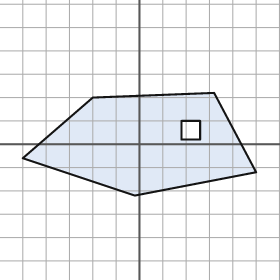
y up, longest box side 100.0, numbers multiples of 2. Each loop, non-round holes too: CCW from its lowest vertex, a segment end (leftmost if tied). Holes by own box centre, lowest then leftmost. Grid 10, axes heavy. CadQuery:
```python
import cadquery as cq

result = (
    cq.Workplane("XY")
    .moveTo(-2.0, -22.0)
    .lineTo(50.0, -12.0)
    .lineTo(32.0, 22.0)
    .lineTo(-20.0, 20.0)
    .lineTo(-50.0, -6.0)
    .close()
    .moveTo(18.0, 2.0)
    .lineTo(26.0, 2.0)
    .lineTo(26.0, 10.0)
    .lineTo(18.0, 10.0)
    .close()
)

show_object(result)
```